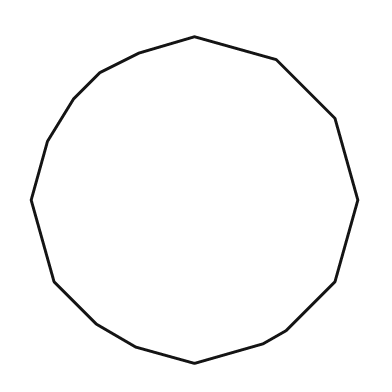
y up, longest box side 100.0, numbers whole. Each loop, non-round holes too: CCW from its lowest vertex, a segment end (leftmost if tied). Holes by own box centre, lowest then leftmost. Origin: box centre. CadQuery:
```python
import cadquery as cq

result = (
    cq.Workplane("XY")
    .moveTo(0.0, -50.0)
    .lineTo(21.0, -44.0)
    .lineTo(28.0, -40.0)
    .lineTo(43.0, -25.0)
    .lineTo(50.0, 0.0)
    .lineTo(43.0, 25.0)
    .lineTo(25.0, 43.0)
    .lineTo(0.0, 50.0)
    .lineTo(-17.0, 45.0)
    .lineTo(-29.0, 39.0)
    .lineTo(-37.0, 31.0)
    .lineTo(-45.0, 18.0)
    .lineTo(-50.0, 0.0)
    .lineTo(-43.0, -25.0)
    .lineTo(-30.0, -38.0)
    .lineTo(-18.0, -45.0)
    .close()
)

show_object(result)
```